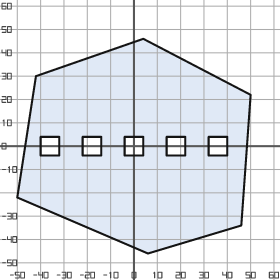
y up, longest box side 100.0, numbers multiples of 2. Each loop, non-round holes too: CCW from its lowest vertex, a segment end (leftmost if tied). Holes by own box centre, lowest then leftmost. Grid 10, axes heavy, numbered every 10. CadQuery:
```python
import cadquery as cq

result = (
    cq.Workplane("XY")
    .moveTo(6.0, -46.0)
    .lineTo(46.0, -34.0)
    .lineTo(50.0, 22.0)
    .lineTo(4.0, 46.0)
    .lineTo(-42.0, 30.0)
    .lineTo(-50.0, -22.0)
    .close()
    .moveTo(-40.0, -4.0)
    .lineTo(-32.0, -4.0)
    .lineTo(-32.0, 4.0)
    .lineTo(-40.0, 4.0)
    .close()
    .moveTo(-22.0, -4.0)
    .lineTo(-14.0, -4.0)
    .lineTo(-14.0, 4.0)
    .lineTo(-22.0, 4.0)
    .close()
    .moveTo(-4.0, -4.0)
    .lineTo(4.0, -4.0)
    .lineTo(4.0, 4.0)
    .lineTo(-4.0, 4.0)
    .close()
    .moveTo(14.0, -4.0)
    .lineTo(22.0, -4.0)
    .lineTo(22.0, 4.0)
    .lineTo(14.0, 4.0)
    .close()
    .moveTo(32.0, -4.0)
    .lineTo(40.0, -4.0)
    .lineTo(40.0, 4.0)
    .lineTo(32.0, 4.0)
    .close()
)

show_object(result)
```